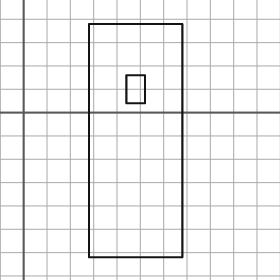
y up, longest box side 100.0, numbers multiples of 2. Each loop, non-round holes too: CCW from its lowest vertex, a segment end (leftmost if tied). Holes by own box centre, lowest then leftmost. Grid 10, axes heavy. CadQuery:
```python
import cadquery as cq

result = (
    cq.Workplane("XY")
    .moveTo(28.0, -62.0)
    .lineTo(68.0, -62.0)
    .lineTo(68.0, 38.0)
    .lineTo(28.0, 38.0)
    .close()
    .moveTo(44.0, 4.0)
    .lineTo(52.0, 4.0)
    .lineTo(52.0, 16.0)
    .lineTo(44.0, 16.0)
    .close()
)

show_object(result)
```